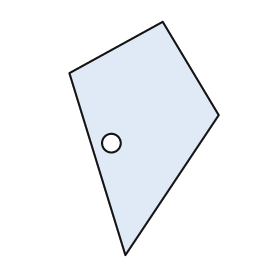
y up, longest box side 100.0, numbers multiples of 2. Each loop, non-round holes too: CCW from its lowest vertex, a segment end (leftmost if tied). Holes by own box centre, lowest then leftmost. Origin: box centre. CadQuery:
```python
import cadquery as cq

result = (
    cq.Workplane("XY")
    .moveTo(-8.0, -50.0)
    .lineTo(32.0, 10.0)
    .lineTo(8.0, 50.0)
    .lineTo(-32.0, 28.0)
    .close()
    .moveTo(-14.0, -2.0)
    .circle(4.0)
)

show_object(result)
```